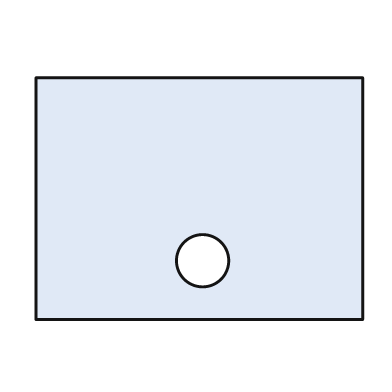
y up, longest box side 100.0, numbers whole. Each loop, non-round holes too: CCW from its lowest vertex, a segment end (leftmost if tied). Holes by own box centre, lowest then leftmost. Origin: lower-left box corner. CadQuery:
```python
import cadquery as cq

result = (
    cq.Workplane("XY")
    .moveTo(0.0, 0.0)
    .lineTo(100.0, 0.0)
    .lineTo(100.0, 74.0)
    .lineTo(0.0, 74.0)
    .close()
    .moveTo(51.0, 18.0)
    .circle(8.0)
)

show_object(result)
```